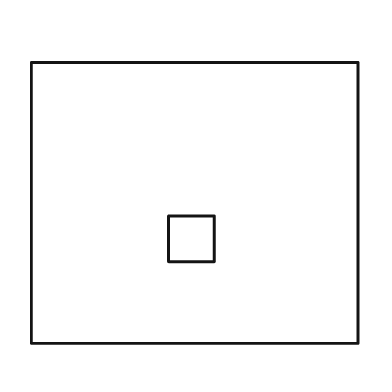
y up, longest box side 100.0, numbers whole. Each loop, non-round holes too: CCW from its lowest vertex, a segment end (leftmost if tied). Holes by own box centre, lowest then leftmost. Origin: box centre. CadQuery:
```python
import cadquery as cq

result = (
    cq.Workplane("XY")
    .moveTo(-50.0, -43.0)
    .lineTo(50.0, -43.0)
    .lineTo(50.0, 43.0)
    .lineTo(-50.0, 43.0)
    .close()
    .moveTo(-8.0, -18.0)
    .lineTo(6.0, -18.0)
    .lineTo(6.0, -4.0)
    .lineTo(-8.0, -4.0)
    .close()
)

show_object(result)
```